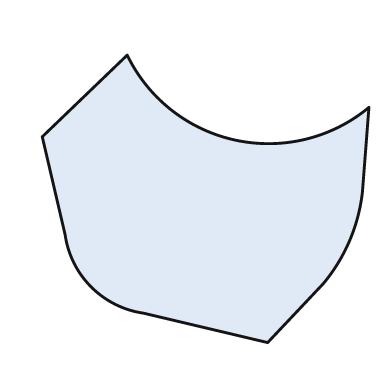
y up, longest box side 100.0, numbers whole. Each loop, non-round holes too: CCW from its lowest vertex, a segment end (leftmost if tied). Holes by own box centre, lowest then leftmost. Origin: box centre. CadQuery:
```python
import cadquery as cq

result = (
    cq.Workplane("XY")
    .moveTo(19.0, -44.0)
    .lineTo(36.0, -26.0)
    .threePointArc((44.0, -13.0), (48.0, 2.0))
    .lineTo(50.0, 28.0)
    .threePointArc((9.0, 18.0), (-24.0, 44.0))
    .lineTo(-50.0, 19.0)
    .lineTo(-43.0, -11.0)
    .threePointArc((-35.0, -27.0), (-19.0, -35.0))
    .close()
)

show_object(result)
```